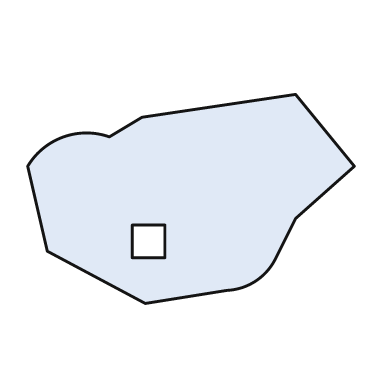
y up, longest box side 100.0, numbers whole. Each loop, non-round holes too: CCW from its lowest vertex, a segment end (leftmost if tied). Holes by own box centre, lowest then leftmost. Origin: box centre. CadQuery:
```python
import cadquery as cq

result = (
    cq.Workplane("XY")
    .moveTo(-14.0, -32.0)
    .lineTo(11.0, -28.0)
    .threePointArc((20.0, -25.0), (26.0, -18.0))
    .lineTo(32.0, -6.0)
    .lineTo(50.0, 10.0)
    .lineTo(32.0, 32.0)
    .lineTo(-15.0, 25.0)
    .lineTo(-25.0, 19.0)
    .threePointArc((-39.0, 19.0), (-50.0, 10.0))
    .lineTo(-44.0, -16.0)
    .close()
    .moveTo(-18.0, -18.0)
    .lineTo(-8.0, -18.0)
    .lineTo(-8.0, -8.0)
    .lineTo(-18.0, -8.0)
    .close()
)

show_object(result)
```